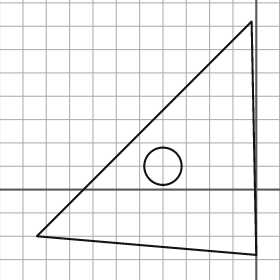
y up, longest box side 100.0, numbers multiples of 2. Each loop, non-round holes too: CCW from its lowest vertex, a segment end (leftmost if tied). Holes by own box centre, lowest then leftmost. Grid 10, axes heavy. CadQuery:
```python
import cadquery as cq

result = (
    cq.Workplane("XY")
    .moveTo(0.0, -28.0)
    .lineTo(-2.0, 72.0)
    .lineTo(-94.0, -20.0)
    .close()
    .moveTo(-40.0, 10.0)
    .circle(8.0)
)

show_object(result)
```